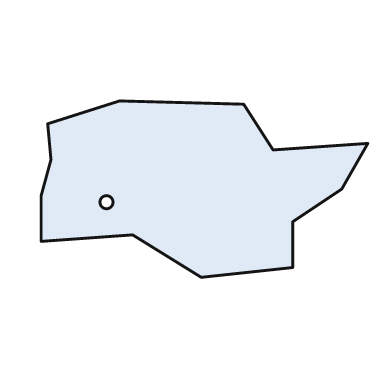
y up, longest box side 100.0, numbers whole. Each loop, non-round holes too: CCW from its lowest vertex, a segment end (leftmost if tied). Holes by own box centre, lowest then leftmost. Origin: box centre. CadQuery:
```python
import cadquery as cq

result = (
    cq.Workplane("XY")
    .moveTo(-1.0, -27.0)
    .lineTo(27.0, -24.0)
    .lineTo(27.0, -10.0)
    .lineTo(42.0, 0.0)
    .lineTo(50.0, 14.0)
    .lineTo(21.0, 12.0)
    .lineTo(12.0, 26.0)
    .lineTo(-26.0, 27.0)
    .lineTo(-48.0, 20.0)
    .lineTo(-47.0, 9.0)
    .lineTo(-50.0, -2.0)
    .lineTo(-50.0, -16.0)
    .lineTo(-22.0, -14.0)
    .close()
    .moveTo(-30.0, -4.0)
    .circle(2.0)
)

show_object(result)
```